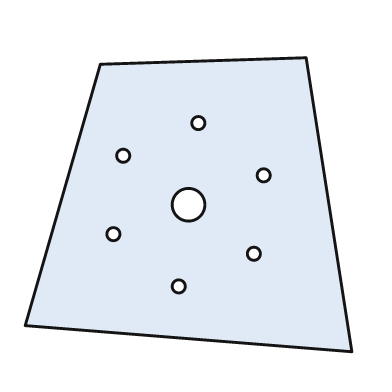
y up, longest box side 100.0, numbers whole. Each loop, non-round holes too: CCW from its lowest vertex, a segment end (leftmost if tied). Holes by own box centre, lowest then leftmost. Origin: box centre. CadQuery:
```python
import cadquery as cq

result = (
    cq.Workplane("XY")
    .moveTo(50.0, -45.0)
    .lineTo(36.0, 45.0)
    .lineTo(-27.0, 43.0)
    .lineTo(-50.0, -37.0)
    .close()
    .moveTo(-3.0, -25.0)
    .circle(2.0)
    .moveTo(20.0, -15.0)
    .circle(2.0)
    .moveTo(-23.0, -9.0)
    .circle(2.0)
    .moveTo(0.0, 0.0)
    .circle(5.0)
    .moveTo(23.0, 9.0)
    .circle(2.0)
    .moveTo(-20.0, 15.0)
    .circle(2.0)
    .moveTo(3.0, 25.0)
    .circle(2.0)
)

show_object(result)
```